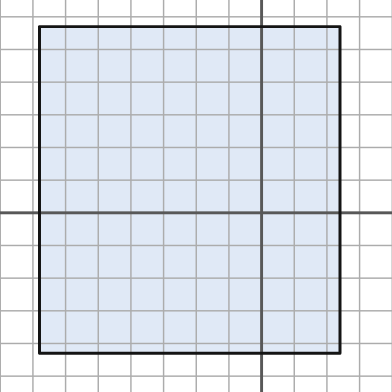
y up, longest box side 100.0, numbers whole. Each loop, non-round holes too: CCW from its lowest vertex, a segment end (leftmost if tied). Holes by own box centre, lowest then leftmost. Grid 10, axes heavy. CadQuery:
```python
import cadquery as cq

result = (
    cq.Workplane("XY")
    .moveTo(-68.0, -43.0)
    .lineTo(24.0, -43.0)
    .lineTo(24.0, 57.0)
    .lineTo(-68.0, 57.0)
    .close()
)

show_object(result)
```